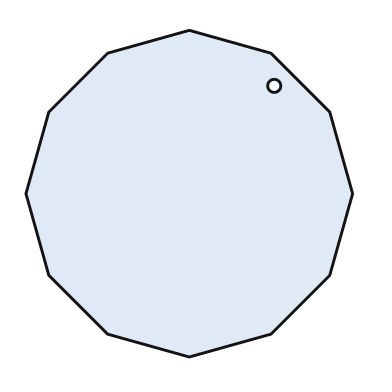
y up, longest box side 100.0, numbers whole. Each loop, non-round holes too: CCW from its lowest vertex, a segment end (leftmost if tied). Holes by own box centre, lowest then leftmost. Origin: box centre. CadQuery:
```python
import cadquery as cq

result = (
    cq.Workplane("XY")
    .moveTo(0.0, -50.0)
    .lineTo(25.0, -43.0)
    .lineTo(43.0, -25.0)
    .lineTo(50.0, 0.0)
    .lineTo(43.0, 25.0)
    .lineTo(25.0, 43.0)
    .lineTo(0.0, 50.0)
    .lineTo(-25.0, 43.0)
    .lineTo(-43.0, 25.0)
    .lineTo(-50.0, 0.0)
    .lineTo(-43.0, -25.0)
    .lineTo(-25.0, -43.0)
    .close()
    .moveTo(26.0, 33.0)
    .circle(2.0)
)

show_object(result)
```